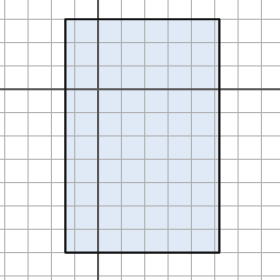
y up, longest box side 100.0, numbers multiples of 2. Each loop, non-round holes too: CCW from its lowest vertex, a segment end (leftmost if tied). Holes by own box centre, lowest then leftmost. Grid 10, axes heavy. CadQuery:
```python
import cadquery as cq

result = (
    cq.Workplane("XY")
    .moveTo(-14.0, -70.0)
    .lineTo(52.0, -70.0)
    .lineTo(52.0, 30.0)
    .lineTo(-14.0, 30.0)
    .close()
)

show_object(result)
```